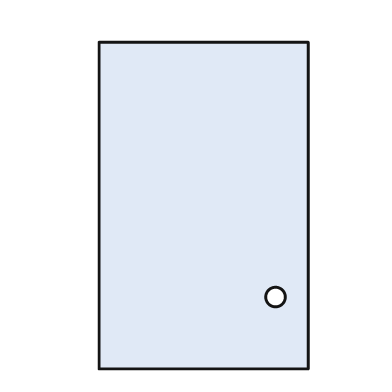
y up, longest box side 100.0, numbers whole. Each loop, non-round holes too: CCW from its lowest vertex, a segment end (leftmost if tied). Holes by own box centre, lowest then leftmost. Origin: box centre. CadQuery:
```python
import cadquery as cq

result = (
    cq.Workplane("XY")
    .moveTo(-32.0, -50.0)
    .lineTo(32.0, -50.0)
    .lineTo(32.0, 50.0)
    .lineTo(-32.0, 50.0)
    .close()
    .moveTo(22.0, -28.0)
    .circle(3.0)
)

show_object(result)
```